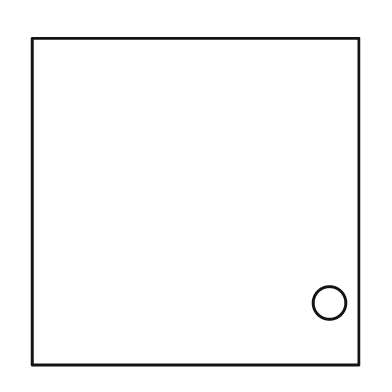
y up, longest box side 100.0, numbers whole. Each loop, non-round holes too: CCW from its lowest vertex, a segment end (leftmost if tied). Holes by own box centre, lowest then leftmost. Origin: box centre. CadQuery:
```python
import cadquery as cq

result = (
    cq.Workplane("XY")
    .moveTo(-50.0, -50.0)
    .lineTo(50.0, -50.0)
    .lineTo(50.0, 50.0)
    .lineTo(-50.0, 50.0)
    .close()
    .moveTo(41.0, -31.0)
    .circle(5.0)
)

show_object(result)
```